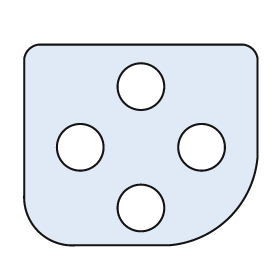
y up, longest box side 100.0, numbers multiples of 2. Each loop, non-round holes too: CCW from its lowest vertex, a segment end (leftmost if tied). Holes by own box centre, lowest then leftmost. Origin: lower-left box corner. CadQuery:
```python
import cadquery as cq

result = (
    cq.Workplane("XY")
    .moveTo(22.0, 0.0)
    .lineTo(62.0, 0.0)
    .threePointArc((88.0, 12.0), (100.0, 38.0))
    .lineTo(100.0, 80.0)
    .threePointArc((98.0, 84.0), (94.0, 86.0))
    .lineTo(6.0, 86.0)
    .threePointArc((2.0, 84.0), (0.0, 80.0))
    .lineTo(0.0, 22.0)
    .threePointArc((6.0, 6.0), (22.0, 0.0))
    .close()
    .moveTo(50.0, 16.0)
    .circle(10.0)
    .moveTo(24.0, 42.0)
    .circle(10.0)
    .moveTo(76.0, 42.0)
    .circle(10.0)
    .moveTo(50.0, 68.0)
    .circle(10.0)
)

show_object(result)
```